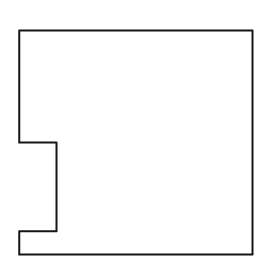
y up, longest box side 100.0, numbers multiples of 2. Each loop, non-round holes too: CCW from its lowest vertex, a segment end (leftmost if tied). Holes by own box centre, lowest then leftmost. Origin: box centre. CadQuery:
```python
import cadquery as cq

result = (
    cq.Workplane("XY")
    .moveTo(-50.0, -48.0)
    .lineTo(50.0, -48.0)
    .lineTo(50.0, 48.0)
    .lineTo(-50.0, 48.0)
    .lineTo(-50.0, 0.0)
    .lineTo(-34.0, 0.0)
    .lineTo(-34.0, -38.0)
    .lineTo(-50.0, -38.0)
    .close()
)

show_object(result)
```